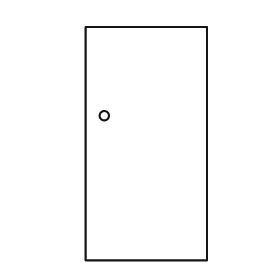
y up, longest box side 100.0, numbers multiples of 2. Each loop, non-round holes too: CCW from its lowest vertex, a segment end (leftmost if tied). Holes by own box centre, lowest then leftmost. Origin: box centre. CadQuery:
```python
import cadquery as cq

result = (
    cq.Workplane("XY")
    .moveTo(-26.0, -50.0)
    .lineTo(26.0, -50.0)
    .lineTo(26.0, 50.0)
    .lineTo(-26.0, 50.0)
    .close()
    .moveTo(-18.0, 12.0)
    .circle(2.0)
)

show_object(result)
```